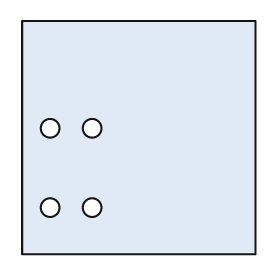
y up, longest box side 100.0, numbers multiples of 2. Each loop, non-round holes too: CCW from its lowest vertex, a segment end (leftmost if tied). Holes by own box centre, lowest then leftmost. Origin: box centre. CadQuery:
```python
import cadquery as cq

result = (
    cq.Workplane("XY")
    .moveTo(-50.0, -50.0)
    .lineTo(50.0, -50.0)
    .lineTo(50.0, 50.0)
    .lineTo(-50.0, 50.0)
    .close()
    .moveTo(-38.0, -30.0)
    .circle(4.0)
    .moveTo(-20.0, -30.0)
    .circle(4.0)
    .moveTo(-38.0, 4.0)
    .circle(4.0)
    .moveTo(-20.0, 4.0)
    .circle(4.0)
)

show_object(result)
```